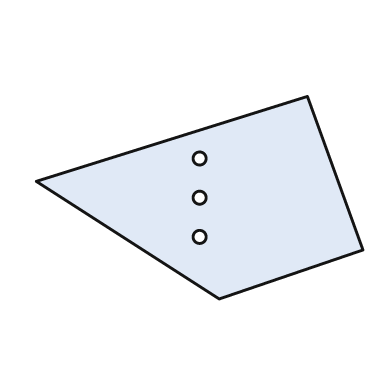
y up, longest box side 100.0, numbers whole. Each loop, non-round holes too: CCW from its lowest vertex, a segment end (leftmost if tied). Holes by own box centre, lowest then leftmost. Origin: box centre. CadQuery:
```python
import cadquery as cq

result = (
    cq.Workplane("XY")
    .moveTo(6.0, -31.0)
    .lineTo(50.0, -16.0)
    .lineTo(33.0, 31.0)
    .lineTo(-50.0, 5.0)
    .close()
    .moveTo(0.0, -12.0)
    .circle(2.0)
    .moveTo(0.0, 0.0)
    .circle(2.0)
    .moveTo(0.0, 12.0)
    .circle(2.0)
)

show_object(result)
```